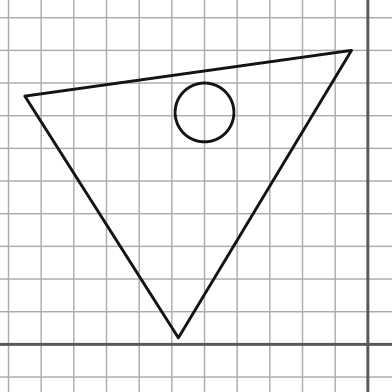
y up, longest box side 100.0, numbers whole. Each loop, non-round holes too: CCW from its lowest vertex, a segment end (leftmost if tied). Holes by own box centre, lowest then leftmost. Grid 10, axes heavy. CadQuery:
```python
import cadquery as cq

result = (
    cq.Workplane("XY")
    .moveTo(-58.0, 2.0)
    .lineTo(-5.0, 90.0)
    .lineTo(-105.0, 76.0)
    .close()
    .moveTo(-50.0, 71.0)
    .circle(9.0)
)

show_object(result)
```